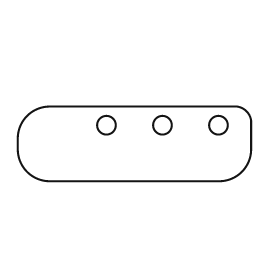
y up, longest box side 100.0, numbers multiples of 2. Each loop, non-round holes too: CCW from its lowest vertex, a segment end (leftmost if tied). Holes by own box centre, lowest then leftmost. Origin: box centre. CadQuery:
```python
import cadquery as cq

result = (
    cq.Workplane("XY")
    .moveTo(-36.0, -16.0)
    .lineTo(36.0, -16.0)
    .threePointArc((46.0, -12.0), (50.0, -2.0))
    .lineTo(50.0, 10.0)
    .threePointArc((48.0, 14.0), (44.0, 16.0))
    .lineTo(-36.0, 16.0)
    .threePointArc((-46.0, 12.0), (-50.0, 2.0))
    .lineTo(-50.0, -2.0)
    .threePointArc((-46.0, -12.0), (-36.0, -16.0))
    .close()
    .moveTo(-12.0, 8.0)
    .circle(4.0)
    .moveTo(12.0, 8.0)
    .circle(4.0)
    .moveTo(36.0, 8.0)
    .circle(4.0)
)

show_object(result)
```